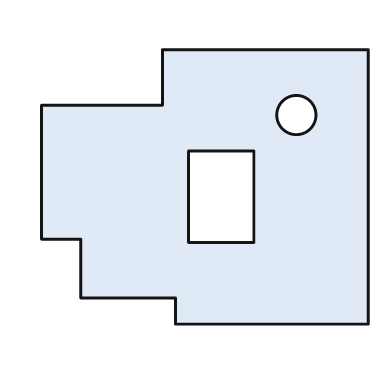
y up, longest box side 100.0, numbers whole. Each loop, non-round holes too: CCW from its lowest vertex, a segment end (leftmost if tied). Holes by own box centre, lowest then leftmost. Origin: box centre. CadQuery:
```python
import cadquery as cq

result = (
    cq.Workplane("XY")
    .moveTo(-9.0, -42.0)
    .lineTo(50.0, -42.0)
    .lineTo(50.0, 42.0)
    .lineTo(-13.0, 42.0)
    .lineTo(-13.0, 25.0)
    .lineTo(-50.0, 25.0)
    .lineTo(-50.0, -16.0)
    .lineTo(-38.0, -16.0)
    .lineTo(-38.0, -34.0)
    .lineTo(-9.0, -34.0)
    .close()
    .moveTo(-5.0, -17.0)
    .lineTo(15.0, -17.0)
    .lineTo(15.0, 11.0)
    .lineTo(-5.0, 11.0)
    .close()
    .moveTo(28.0, 22.0)
    .circle(6.0)
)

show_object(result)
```